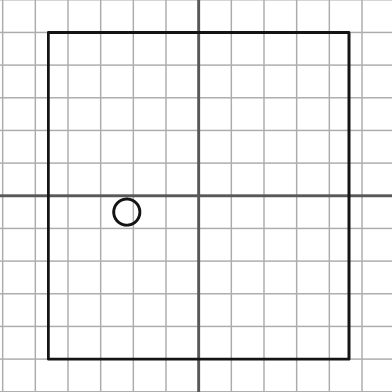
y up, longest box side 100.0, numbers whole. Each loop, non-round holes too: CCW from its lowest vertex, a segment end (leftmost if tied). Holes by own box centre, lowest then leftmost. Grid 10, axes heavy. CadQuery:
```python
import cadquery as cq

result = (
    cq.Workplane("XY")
    .moveTo(-46.0, -50.0)
    .lineTo(46.0, -50.0)
    .lineTo(46.0, 50.0)
    .lineTo(-46.0, 50.0)
    .close()
    .moveTo(-22.0, -5.0)
    .circle(4.0)
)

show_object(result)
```